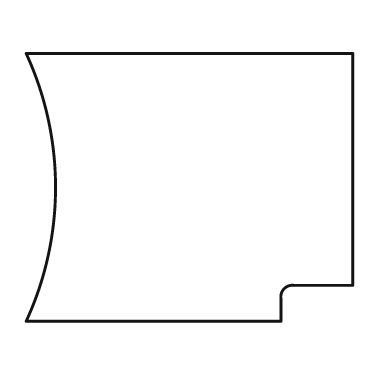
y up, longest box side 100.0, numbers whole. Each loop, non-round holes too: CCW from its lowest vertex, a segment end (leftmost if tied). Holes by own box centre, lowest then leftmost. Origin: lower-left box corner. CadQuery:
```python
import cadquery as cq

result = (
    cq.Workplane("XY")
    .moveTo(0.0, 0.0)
    .lineTo(78.0, 0.0)
    .lineTo(78.0, 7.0)
    .threePointArc((79.0, 10.0), (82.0, 11.0))
    .lineTo(100.0, 11.0)
    .lineTo(100.0, 82.0)
    .lineTo(0.0, 82.0)
    .threePointArc((9.0, 41.0), (0.0, 0.0))
    .close()
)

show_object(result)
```